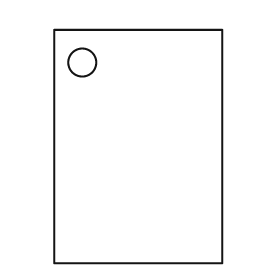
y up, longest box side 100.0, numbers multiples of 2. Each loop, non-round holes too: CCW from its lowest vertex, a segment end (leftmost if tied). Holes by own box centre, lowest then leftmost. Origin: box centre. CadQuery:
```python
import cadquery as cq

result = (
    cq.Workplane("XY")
    .moveTo(-36.0, -50.0)
    .lineTo(36.0, -50.0)
    .lineTo(36.0, 50.0)
    .lineTo(-36.0, 50.0)
    .close()
    .moveTo(-24.0, 36.0)
    .circle(6.0)
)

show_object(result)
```